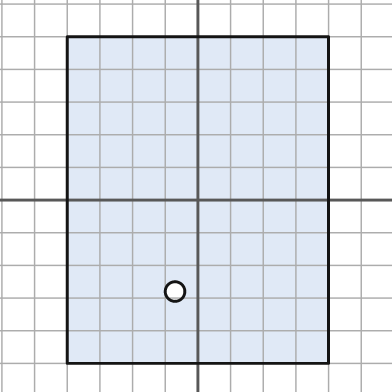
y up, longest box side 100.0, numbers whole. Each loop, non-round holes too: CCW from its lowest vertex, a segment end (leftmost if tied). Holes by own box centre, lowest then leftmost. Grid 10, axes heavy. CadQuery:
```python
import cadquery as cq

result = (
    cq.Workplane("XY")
    .moveTo(-40.0, -50.0)
    .lineTo(40.0, -50.0)
    .lineTo(40.0, 50.0)
    .lineTo(-40.0, 50.0)
    .close()
    .moveTo(-7.0, -28.0)
    .circle(3.0)
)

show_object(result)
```